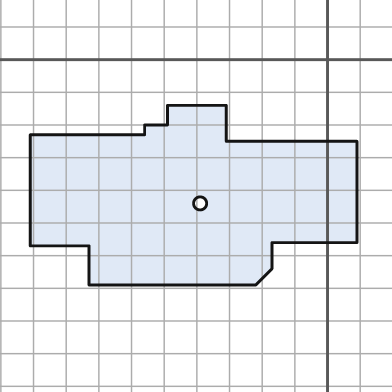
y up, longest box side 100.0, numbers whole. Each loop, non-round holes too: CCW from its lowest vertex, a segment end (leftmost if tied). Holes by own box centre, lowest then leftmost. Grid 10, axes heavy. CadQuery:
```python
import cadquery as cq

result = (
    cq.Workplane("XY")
    .moveTo(-73.0, -69.0)
    .lineTo(-22.0, -69.0)
    .lineTo(-17.0, -64.0)
    .lineTo(-17.0, -56.0)
    .lineTo(9.0, -56.0)
    .lineTo(9.0, -25.0)
    .lineTo(-31.0, -25.0)
    .lineTo(-31.0, -14.0)
    .lineTo(-49.0, -14.0)
    .lineTo(-49.0, -20.0)
    .lineTo(-56.0, -20.0)
    .lineTo(-56.0, -23.0)
    .lineTo(-91.0, -23.0)
    .lineTo(-91.0, -57.0)
    .lineTo(-73.0, -57.0)
    .close()
    .moveTo(-39.0, -44.0)
    .circle(2.0)
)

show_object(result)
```